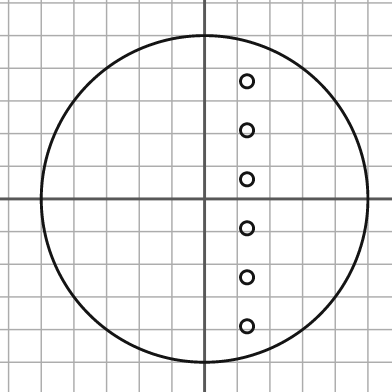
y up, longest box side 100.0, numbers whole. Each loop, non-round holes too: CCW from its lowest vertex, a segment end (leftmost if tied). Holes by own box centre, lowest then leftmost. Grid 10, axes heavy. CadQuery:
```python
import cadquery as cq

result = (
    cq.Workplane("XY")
    .moveTo(0.0, 0.0)
    .circle(50.0)
    .moveTo(13.0, -39.0)
    .circle(2.0)
    .moveTo(13.0, -24.0)
    .circle(2.0)
    .moveTo(13.0, -9.0)
    .circle(2.0)
    .moveTo(13.0, 6.0)
    .circle(2.0)
    .moveTo(13.0, 21.0)
    .circle(2.0)
    .moveTo(13.0, 36.0)
    .circle(2.0)
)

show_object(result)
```